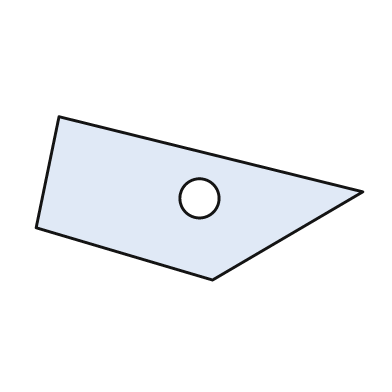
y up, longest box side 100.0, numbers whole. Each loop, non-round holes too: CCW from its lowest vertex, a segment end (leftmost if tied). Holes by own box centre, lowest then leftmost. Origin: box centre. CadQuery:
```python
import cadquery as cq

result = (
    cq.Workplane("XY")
    .moveTo(4.0, -25.0)
    .lineTo(50.0, 2.0)
    .lineTo(-43.0, 25.0)
    .lineTo(-50.0, -9.0)
    .close()
    .moveTo(0.0, 0.0)
    .circle(6.0)
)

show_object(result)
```